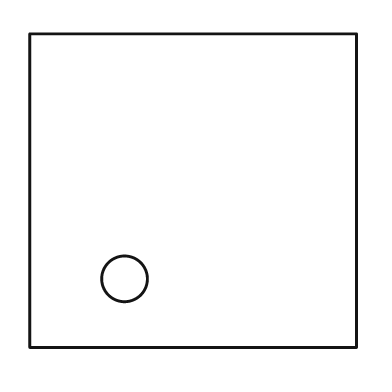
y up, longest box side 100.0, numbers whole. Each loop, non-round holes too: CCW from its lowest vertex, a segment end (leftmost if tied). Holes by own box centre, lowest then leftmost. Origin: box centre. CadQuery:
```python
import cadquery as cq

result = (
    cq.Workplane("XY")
    .moveTo(-50.0, -48.0)
    .lineTo(50.0, -48.0)
    .lineTo(50.0, 48.0)
    .lineTo(-50.0, 48.0)
    .close()
    .moveTo(-21.0, -27.0)
    .circle(7.0)
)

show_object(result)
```